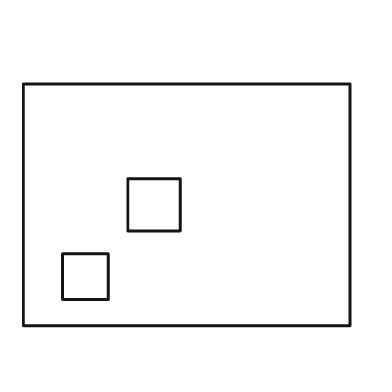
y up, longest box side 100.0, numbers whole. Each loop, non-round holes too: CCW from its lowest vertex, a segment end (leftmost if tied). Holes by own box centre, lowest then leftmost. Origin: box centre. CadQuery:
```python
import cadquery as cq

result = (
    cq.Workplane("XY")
    .moveTo(-50.0, -37.0)
    .lineTo(50.0, -37.0)
    .lineTo(50.0, 37.0)
    .lineTo(-50.0, 37.0)
    .close()
    .moveTo(-38.0, -29.0)
    .lineTo(-24.0, -29.0)
    .lineTo(-24.0, -15.0)
    .lineTo(-38.0, -15.0)
    .close()
    .moveTo(-18.0, -8.0)
    .lineTo(-2.0, -8.0)
    .lineTo(-2.0, 8.0)
    .lineTo(-18.0, 8.0)
    .close()
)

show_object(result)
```